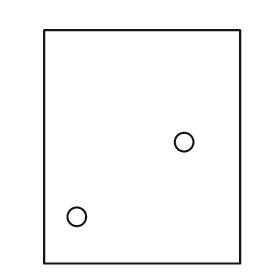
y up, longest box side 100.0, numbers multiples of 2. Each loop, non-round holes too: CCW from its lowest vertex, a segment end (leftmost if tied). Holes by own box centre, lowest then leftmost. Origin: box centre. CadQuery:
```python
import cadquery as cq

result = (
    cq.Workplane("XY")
    .moveTo(-42.0, -50.0)
    .lineTo(42.0, -50.0)
    .lineTo(42.0, 50.0)
    .lineTo(-42.0, 50.0)
    .close()
    .moveTo(-28.0, -30.0)
    .circle(4.0)
    .moveTo(18.0, 2.0)
    .circle(4.0)
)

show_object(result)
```